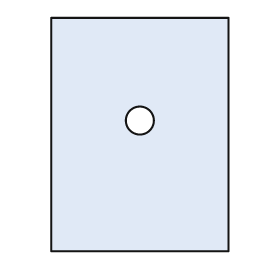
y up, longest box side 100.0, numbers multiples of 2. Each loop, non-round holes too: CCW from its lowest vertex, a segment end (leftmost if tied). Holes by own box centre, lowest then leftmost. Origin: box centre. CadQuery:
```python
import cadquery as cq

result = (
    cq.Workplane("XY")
    .moveTo(-38.0, -50.0)
    .lineTo(38.0, -50.0)
    .lineTo(38.0, 50.0)
    .lineTo(-38.0, 50.0)
    .close()
    .moveTo(0.0, 6.0)
    .circle(6.0)
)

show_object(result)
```